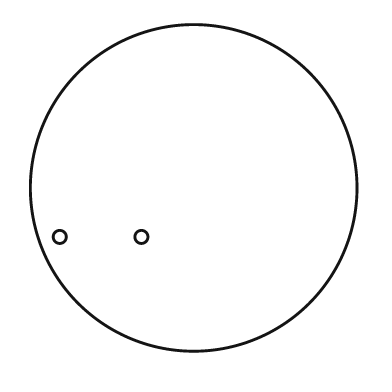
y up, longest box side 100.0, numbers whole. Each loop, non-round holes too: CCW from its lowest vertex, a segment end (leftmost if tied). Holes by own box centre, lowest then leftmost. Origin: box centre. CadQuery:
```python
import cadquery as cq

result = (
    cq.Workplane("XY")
    .moveTo(0.0, 0.0)
    .circle(50.0)
    .moveTo(-41.0, -15.0)
    .circle(2.0)
    .moveTo(-16.0, -15.0)
    .circle(2.0)
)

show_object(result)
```